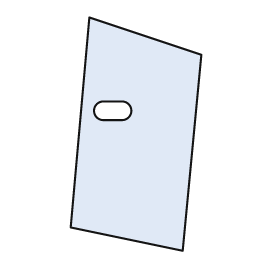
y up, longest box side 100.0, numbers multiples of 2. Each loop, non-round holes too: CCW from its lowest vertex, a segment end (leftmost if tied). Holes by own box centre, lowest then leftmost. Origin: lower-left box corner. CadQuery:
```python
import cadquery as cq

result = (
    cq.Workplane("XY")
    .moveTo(48.0, 0.0)
    .lineTo(56.0, 84.0)
    .lineTo(8.0, 100.0)
    .lineTo(0.0, 10.0)
    .close()
    .moveTo(14.0, 56.0)
    .lineTo(22.0, 56.0)
    .threePointArc((26.0, 60.0), (22.0, 64.0))
    .lineTo(14.0, 64.0)
    .threePointArc((10.0, 60.0), (14.0, 56.0))
    .close()
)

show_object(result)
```